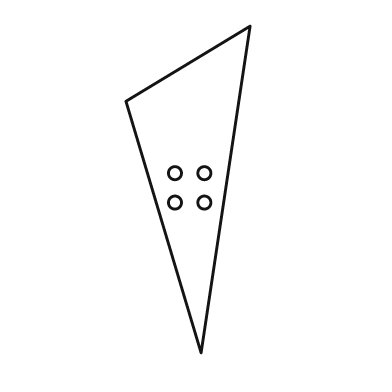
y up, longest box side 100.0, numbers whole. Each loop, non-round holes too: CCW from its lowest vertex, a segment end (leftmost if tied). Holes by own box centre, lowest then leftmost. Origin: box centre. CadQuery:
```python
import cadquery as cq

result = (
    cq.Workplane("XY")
    .moveTo(4.0, -50.0)
    .lineTo(19.0, 50.0)
    .lineTo(-19.0, 27.0)
    .close()
    .moveTo(-4.0, -4.0)
    .circle(2.0)
    .moveTo(5.0, -4.0)
    .circle(2.0)
    .moveTo(-4.0, 5.0)
    .circle(2.0)
    .moveTo(5.0, 5.0)
    .circle(2.0)
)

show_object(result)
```